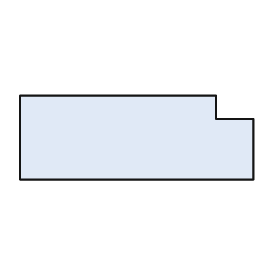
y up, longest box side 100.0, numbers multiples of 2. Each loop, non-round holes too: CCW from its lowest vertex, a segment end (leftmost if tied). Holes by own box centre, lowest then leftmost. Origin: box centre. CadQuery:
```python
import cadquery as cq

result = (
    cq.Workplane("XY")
    .moveTo(-50.0, -18.0)
    .lineTo(50.0, -18.0)
    .lineTo(50.0, 8.0)
    .lineTo(34.0, 8.0)
    .lineTo(34.0, 18.0)
    .lineTo(-50.0, 18.0)
    .close()
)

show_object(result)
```